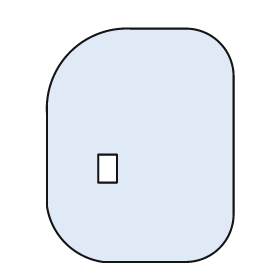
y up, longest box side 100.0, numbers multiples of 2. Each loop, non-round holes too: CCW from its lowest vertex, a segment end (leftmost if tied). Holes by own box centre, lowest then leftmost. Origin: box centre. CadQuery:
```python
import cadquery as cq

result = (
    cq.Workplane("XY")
    .moveTo(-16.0, -50.0)
    .lineTo(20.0, -50.0)
    .threePointArc((34.0, -44.0), (40.0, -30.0))
    .lineTo(40.0, 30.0)
    .threePointArc((34.0, 44.0), (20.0, 50.0))
    .lineTo(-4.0, 50.0)
    .threePointArc((-30.0, 40.0), (-40.0, 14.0))
    .lineTo(-40.0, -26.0)
    .threePointArc((-32.0, -42.0), (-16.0, -50.0))
    .close()
    .moveTo(-18.0, -16.0)
    .lineTo(-10.0, -16.0)
    .lineTo(-10.0, -4.0)
    .lineTo(-18.0, -4.0)
    .close()
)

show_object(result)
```